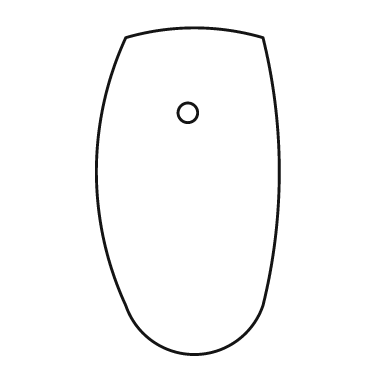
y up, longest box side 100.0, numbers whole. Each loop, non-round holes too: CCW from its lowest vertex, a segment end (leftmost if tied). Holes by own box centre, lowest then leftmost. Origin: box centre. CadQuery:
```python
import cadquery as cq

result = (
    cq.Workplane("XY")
    .moveTo(-19.0, -35.0)
    .threePointArc((2.0, -50.0), (23.0, -35.0))
    .threePointArc((28.0, 6.0), (23.0, 47.0))
    .threePointArc((2.0, 50.0), (-19.0, 47.0))
    .threePointArc((-28.0, 6.0), (-19.0, -35.0))
    .close()
    .moveTo(0.0, 24.0)
    .circle(3.0)
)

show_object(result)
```